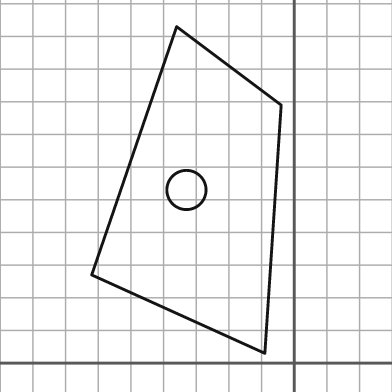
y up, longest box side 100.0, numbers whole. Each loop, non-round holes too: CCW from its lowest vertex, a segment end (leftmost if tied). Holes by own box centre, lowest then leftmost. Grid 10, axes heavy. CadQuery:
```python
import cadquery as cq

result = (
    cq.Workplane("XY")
    .moveTo(-9.0, 3.0)
    .lineTo(-4.0, 79.0)
    .lineTo(-36.0, 103.0)
    .lineTo(-62.0, 27.0)
    .close()
    .moveTo(-33.0, 53.0)
    .circle(6.0)
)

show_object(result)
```